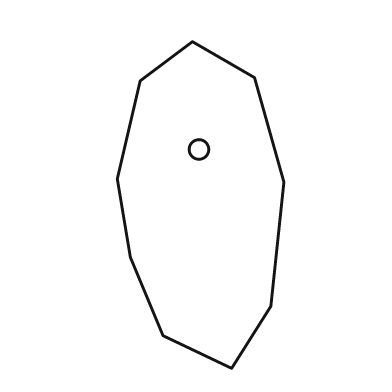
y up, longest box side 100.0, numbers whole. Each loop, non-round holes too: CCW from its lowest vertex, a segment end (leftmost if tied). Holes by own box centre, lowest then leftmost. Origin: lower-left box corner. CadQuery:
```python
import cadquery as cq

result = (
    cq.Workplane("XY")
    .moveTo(35.0, 0.0)
    .lineTo(47.0, 19.0)
    .lineTo(51.0, 57.0)
    .lineTo(42.0, 89.0)
    .lineTo(23.0, 100.0)
    .lineTo(7.0, 88.0)
    .lineTo(0.0, 58.0)
    .lineTo(4.0, 34.0)
    .lineTo(14.0, 10.0)
    .close()
    .moveTo(25.0, 67.0)
    .circle(3.0)
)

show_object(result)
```